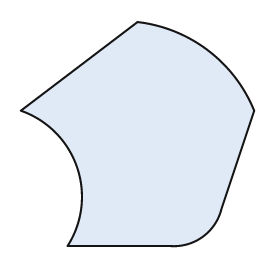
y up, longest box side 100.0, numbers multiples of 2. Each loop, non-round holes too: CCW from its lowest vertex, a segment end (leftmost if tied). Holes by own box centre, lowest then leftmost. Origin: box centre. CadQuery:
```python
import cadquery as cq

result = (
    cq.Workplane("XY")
    .moveTo(-30.0, -48.0)
    .lineTo(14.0, -48.0)
    .threePointArc((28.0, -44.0), (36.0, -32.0))
    .lineTo(50.0, 10.0)
    .threePointArc((30.0, 36.0), (0.0, 48.0))
    .lineTo(-50.0, 10.0)
    .threePointArc((-26.0, -14.0), (-30.0, -48.0))
    .close()
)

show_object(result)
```